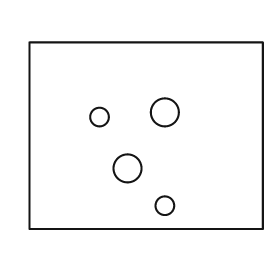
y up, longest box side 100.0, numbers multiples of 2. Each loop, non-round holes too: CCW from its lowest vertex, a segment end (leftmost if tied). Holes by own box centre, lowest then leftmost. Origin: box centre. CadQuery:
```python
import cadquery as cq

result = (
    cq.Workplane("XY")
    .moveTo(-50.0, -40.0)
    .lineTo(50.0, -40.0)
    .lineTo(50.0, 40.0)
    .lineTo(-50.0, 40.0)
    .close()
    .moveTo(8.0, -30.0)
    .circle(4.0)
    .moveTo(-8.0, -14.0)
    .circle(6.0)
    .moveTo(-20.0, 8.0)
    .circle(4.0)
    .moveTo(8.0, 10.0)
    .circle(6.0)
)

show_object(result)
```